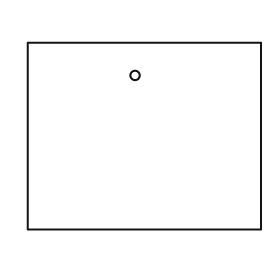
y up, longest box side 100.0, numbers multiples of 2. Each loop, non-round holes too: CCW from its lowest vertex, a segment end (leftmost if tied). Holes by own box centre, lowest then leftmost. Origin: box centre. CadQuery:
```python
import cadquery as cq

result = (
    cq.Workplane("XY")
    .moveTo(-50.0, -40.0)
    .lineTo(50.0, -40.0)
    .lineTo(50.0, 40.0)
    .lineTo(-50.0, 40.0)
    .close()
    .moveTo(-4.0, 26.0)
    .circle(2.0)
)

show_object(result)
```